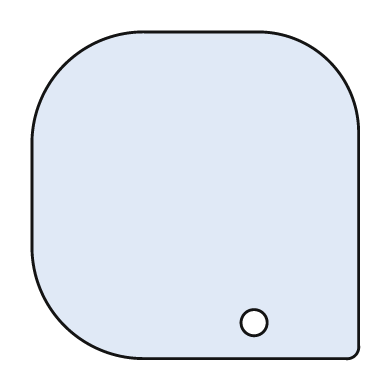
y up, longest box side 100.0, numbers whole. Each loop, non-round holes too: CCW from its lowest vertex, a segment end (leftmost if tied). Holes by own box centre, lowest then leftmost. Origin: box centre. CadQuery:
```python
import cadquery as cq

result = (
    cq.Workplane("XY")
    .moveTo(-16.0, -50.0)
    .lineTo(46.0, -50.0)
    .threePointArc((49.0, -49.0), (50.0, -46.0))
    .lineTo(50.0, 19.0)
    .threePointArc((41.0, 41.0), (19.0, 50.0))
    .lineTo(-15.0, 50.0)
    .threePointArc((-40.0, 40.0), (-50.0, 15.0))
    .lineTo(-50.0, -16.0)
    .threePointArc((-40.0, -40.0), (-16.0, -50.0))
    .close()
    .moveTo(18.0, -39.0)
    .circle(4.0)
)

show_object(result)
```